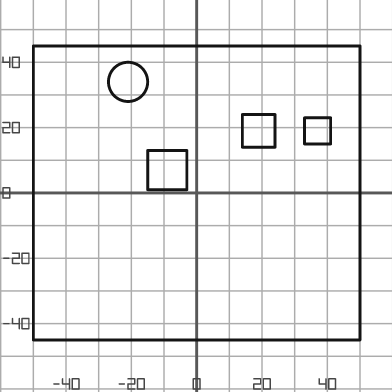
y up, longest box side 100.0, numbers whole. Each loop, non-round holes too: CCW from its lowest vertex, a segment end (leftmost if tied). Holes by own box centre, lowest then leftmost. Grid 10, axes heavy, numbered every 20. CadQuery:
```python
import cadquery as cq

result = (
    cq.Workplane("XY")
    .moveTo(-50.0, -45.0)
    .lineTo(50.0, -45.0)
    .lineTo(50.0, 45.0)
    .lineTo(-50.0, 45.0)
    .close()
    .moveTo(-15.0, 1.0)
    .lineTo(-3.0, 1.0)
    .lineTo(-3.0, 13.0)
    .lineTo(-15.0, 13.0)
    .close()
    .moveTo(14.0, 14.0)
    .lineTo(24.0, 14.0)
    .lineTo(24.0, 24.0)
    .lineTo(14.0, 24.0)
    .close()
    .moveTo(33.0, 15.0)
    .lineTo(41.0, 15.0)
    .lineTo(41.0, 23.0)
    .lineTo(33.0, 23.0)
    .close()
    .moveTo(-21.0, 34.0)
    .circle(6.0)
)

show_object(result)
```